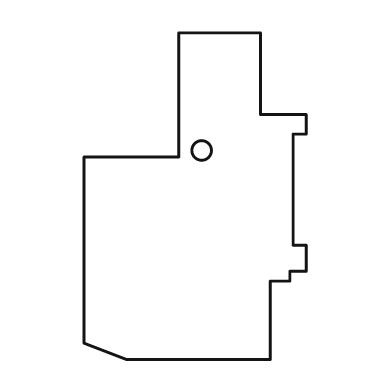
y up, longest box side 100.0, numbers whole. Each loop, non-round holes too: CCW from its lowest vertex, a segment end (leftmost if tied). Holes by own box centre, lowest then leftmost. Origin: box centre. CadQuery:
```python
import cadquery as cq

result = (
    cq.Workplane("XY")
    .moveTo(-21.0, -50.0)
    .lineTo(23.0, -50.0)
    .lineTo(23.0, -26.0)
    .lineTo(29.0, -26.0)
    .lineTo(29.0, -23.0)
    .lineTo(34.0, -23.0)
    .lineTo(34.0, -15.0)
    .lineTo(30.0, -15.0)
    .lineTo(30.0, 19.0)
    .lineTo(34.0, 19.0)
    .lineTo(34.0, 25.0)
    .lineTo(20.0, 25.0)
    .lineTo(20.0, 50.0)
    .lineTo(-5.0, 50.0)
    .lineTo(-5.0, 12.0)
    .lineTo(-34.0, 12.0)
    .lineTo(-34.0, -45.0)
    .close()
    .moveTo(2.0, 14.0)
    .circle(3.0)
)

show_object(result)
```